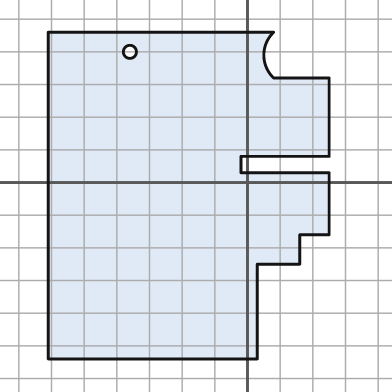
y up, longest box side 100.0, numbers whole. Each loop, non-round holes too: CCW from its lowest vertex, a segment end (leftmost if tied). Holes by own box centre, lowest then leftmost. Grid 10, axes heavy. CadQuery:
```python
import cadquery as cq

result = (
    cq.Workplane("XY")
    .moveTo(-61.0, -54.0)
    .lineTo(3.0, -54.0)
    .lineTo(3.0, -25.0)
    .lineTo(16.0, -25.0)
    .lineTo(16.0, -16.0)
    .lineTo(25.0, -16.0)
    .lineTo(25.0, 3.0)
    .lineTo(-2.0, 3.0)
    .lineTo(-2.0, 8.0)
    .lineTo(25.0, 8.0)
    .lineTo(25.0, 32.0)
    .lineTo(8.0, 32.0)
    .threePointArc((5.0, 39.0), (8.0, 46.0))
    .lineTo(-61.0, 46.0)
    .close()
    .moveTo(-36.0, 40.0)
    .circle(2.0)
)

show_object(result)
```